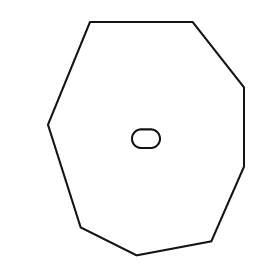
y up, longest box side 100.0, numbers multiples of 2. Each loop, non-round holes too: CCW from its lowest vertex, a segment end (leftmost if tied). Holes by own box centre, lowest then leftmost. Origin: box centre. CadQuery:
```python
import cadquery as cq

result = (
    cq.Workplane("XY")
    .moveTo(-4.0, -50.0)
    .lineTo(28.0, -44.0)
    .lineTo(42.0, -12.0)
    .lineTo(42.0, 22.0)
    .lineTo(20.0, 50.0)
    .lineTo(-24.0, 50.0)
    .lineTo(-42.0, 6.0)
    .lineTo(-28.0, -38.0)
    .close()
    .moveTo(-2.0, -4.0)
    .lineTo(2.0, -4.0)
    .threePointArc((6.0, 0.0), (2.0, 4.0))
    .lineTo(-2.0, 4.0)
    .threePointArc((-6.0, 0.0), (-2.0, -4.0))
    .close()
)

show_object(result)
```